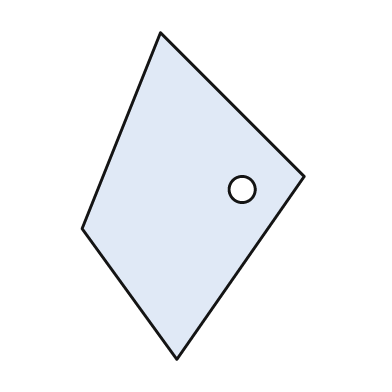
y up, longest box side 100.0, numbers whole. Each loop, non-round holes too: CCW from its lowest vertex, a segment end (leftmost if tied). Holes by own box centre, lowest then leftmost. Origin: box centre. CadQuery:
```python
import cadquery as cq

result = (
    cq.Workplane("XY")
    .moveTo(-5.0, -50.0)
    .lineTo(34.0, 6.0)
    .lineTo(-10.0, 50.0)
    .lineTo(-34.0, -10.0)
    .close()
    .moveTo(15.0, 2.0)
    .circle(4.0)
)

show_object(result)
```